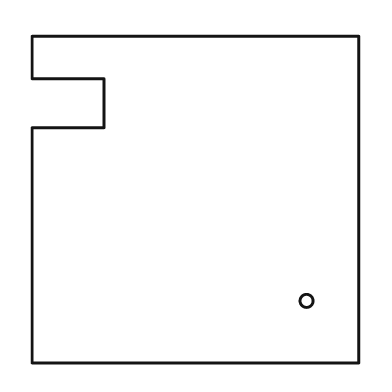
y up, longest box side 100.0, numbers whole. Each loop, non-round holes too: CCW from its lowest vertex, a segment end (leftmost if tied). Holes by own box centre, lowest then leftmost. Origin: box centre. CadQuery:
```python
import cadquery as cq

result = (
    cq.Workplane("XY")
    .moveTo(-50.0, -50.0)
    .lineTo(50.0, -50.0)
    .lineTo(50.0, 50.0)
    .lineTo(-50.0, 50.0)
    .lineTo(-50.0, 37.0)
    .lineTo(-28.0, 37.0)
    .lineTo(-28.0, 22.0)
    .lineTo(-50.0, 22.0)
    .close()
    .moveTo(34.0, -31.0)
    .circle(2.0)
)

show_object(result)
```